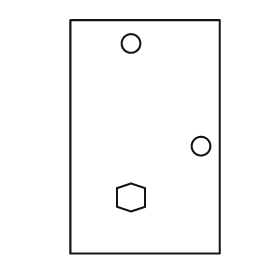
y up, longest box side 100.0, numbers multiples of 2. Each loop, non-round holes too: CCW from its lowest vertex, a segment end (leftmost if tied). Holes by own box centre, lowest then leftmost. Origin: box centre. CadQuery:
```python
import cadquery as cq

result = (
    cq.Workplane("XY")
    .moveTo(-32.0, -50.0)
    .lineTo(32.0, -50.0)
    .lineTo(32.0, 50.0)
    .lineTo(-32.0, 50.0)
    .close()
    .moveTo(-6.0, -32.0)
    .lineTo(0.0, -30.0)
    .lineTo(0.0, -22.0)
    .lineTo(-6.0, -20.0)
    .lineTo(-12.0, -22.0)
    .lineTo(-12.0, -30.0)
    .close()
    .moveTo(24.0, -4.0)
    .circle(4.0)
    .moveTo(-6.0, 40.0)
    .circle(4.0)
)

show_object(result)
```